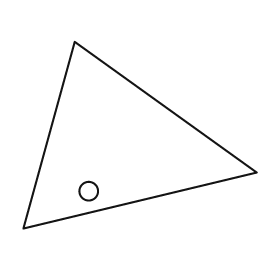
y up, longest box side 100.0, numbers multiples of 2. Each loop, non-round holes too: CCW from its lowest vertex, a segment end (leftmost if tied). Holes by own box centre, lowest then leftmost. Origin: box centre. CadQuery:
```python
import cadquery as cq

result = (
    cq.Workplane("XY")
    .moveTo(-50.0, -40.0)
    .lineTo(50.0, -16.0)
    .lineTo(-28.0, 40.0)
    .close()
    .moveTo(-22.0, -24.0)
    .circle(4.0)
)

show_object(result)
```